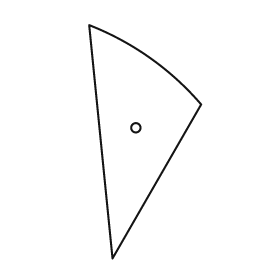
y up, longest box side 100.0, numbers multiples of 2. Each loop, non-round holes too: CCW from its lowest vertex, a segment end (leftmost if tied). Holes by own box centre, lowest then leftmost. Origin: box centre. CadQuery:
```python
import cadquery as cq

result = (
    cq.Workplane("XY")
    .moveTo(-14.0, -50.0)
    .lineTo(24.0, 16.0)
    .threePointArc((2.0, 36.0), (-24.0, 50.0))
    .close()
    .moveTo(-4.0, 6.0)
    .circle(2.0)
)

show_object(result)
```